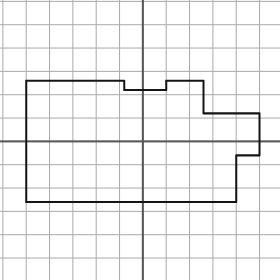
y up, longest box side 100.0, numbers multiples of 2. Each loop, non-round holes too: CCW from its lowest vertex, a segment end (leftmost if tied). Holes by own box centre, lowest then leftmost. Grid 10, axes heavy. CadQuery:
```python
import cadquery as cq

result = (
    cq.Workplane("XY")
    .moveTo(-50.0, -26.0)
    .lineTo(40.0, -26.0)
    .lineTo(40.0, -6.0)
    .lineTo(50.0, -6.0)
    .lineTo(50.0, 12.0)
    .lineTo(26.0, 12.0)
    .lineTo(26.0, 26.0)
    .lineTo(10.0, 26.0)
    .lineTo(10.0, 22.0)
    .lineTo(-8.0, 22.0)
    .lineTo(-8.0, 26.0)
    .lineTo(-50.0, 26.0)
    .close()
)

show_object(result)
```